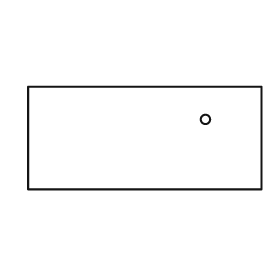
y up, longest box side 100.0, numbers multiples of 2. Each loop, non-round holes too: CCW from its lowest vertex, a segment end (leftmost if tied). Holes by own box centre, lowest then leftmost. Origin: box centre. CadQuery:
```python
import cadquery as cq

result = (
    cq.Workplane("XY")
    .moveTo(-50.0, -22.0)
    .lineTo(50.0, -22.0)
    .lineTo(50.0, 22.0)
    .lineTo(-50.0, 22.0)
    .close()
    .moveTo(26.0, 8.0)
    .circle(2.0)
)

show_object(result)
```